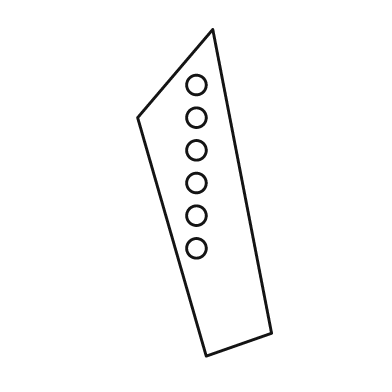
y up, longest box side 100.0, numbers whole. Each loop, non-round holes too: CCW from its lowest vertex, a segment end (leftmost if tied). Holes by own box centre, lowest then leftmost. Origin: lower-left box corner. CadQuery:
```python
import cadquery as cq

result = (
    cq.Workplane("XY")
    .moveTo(21.0, 0.0)
    .lineTo(41.0, 7.0)
    .lineTo(23.0, 100.0)
    .lineTo(0.0, 73.0)
    .close()
    .moveTo(18.0, 33.0)
    .circle(3.0)
    .moveTo(18.0, 43.0)
    .circle(3.0)
    .moveTo(18.0, 53.0)
    .circle(3.0)
    .moveTo(18.0, 63.0)
    .circle(3.0)
    .moveTo(18.0, 73.0)
    .circle(3.0)
    .moveTo(18.0, 83.0)
    .circle(3.0)
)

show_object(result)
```